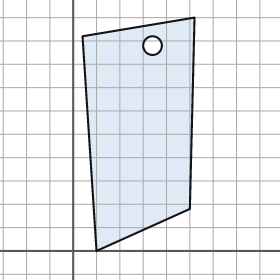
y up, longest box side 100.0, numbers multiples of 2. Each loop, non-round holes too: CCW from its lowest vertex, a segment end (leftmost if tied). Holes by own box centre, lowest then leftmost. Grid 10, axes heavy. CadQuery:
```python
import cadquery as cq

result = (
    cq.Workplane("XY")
    .moveTo(10.0, 0.0)
    .lineTo(50.0, 18.0)
    .lineTo(52.0, 100.0)
    .lineTo(4.0, 92.0)
    .close()
    .moveTo(34.0, 88.0)
    .circle(4.0)
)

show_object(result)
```